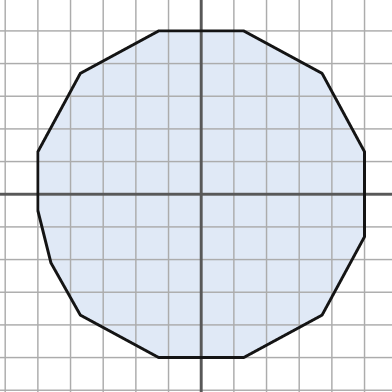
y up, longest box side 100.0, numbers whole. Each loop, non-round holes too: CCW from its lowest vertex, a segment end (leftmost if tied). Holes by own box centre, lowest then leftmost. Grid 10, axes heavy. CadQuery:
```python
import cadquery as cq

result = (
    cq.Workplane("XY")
    .moveTo(-13.0, -50.0)
    .lineTo(13.0, -50.0)
    .lineTo(37.0, -37.0)
    .lineTo(50.0, -13.0)
    .lineTo(50.0, 13.0)
    .lineTo(37.0, 37.0)
    .lineTo(13.0, 50.0)
    .lineTo(-13.0, 50.0)
    .lineTo(-37.0, 37.0)
    .lineTo(-50.0, 13.0)
    .lineTo(-50.0, -5.0)
    .lineTo(-46.0, -21.0)
    .lineTo(-37.0, -37.0)
    .close()
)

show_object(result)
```